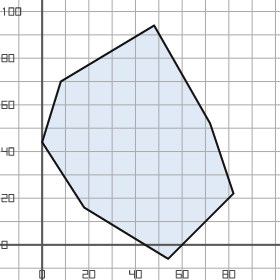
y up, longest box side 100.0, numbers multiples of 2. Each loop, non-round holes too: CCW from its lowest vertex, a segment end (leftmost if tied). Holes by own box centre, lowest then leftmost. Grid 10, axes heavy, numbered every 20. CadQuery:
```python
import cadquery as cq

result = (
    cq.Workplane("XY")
    .moveTo(54.0, -6.0)
    .lineTo(82.0, 22.0)
    .lineTo(72.0, 52.0)
    .lineTo(48.0, 94.0)
    .lineTo(8.0, 70.0)
    .lineTo(0.0, 44.0)
    .lineTo(18.0, 16.0)
    .close()
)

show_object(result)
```